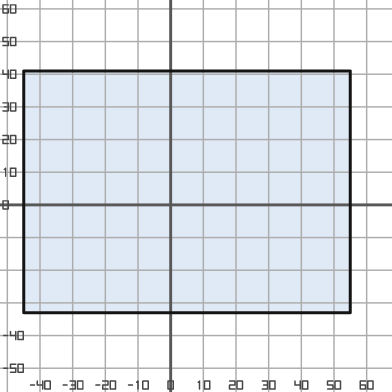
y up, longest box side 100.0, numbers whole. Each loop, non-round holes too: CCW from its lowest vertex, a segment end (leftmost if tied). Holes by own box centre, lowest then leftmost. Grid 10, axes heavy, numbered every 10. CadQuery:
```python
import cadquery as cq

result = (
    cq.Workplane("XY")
    .moveTo(-45.0, -33.0)
    .lineTo(55.0, -33.0)
    .lineTo(55.0, 41.0)
    .lineTo(-45.0, 41.0)
    .close()
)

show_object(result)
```